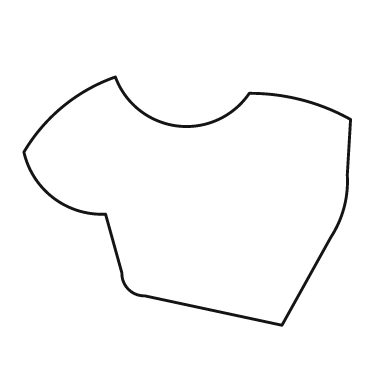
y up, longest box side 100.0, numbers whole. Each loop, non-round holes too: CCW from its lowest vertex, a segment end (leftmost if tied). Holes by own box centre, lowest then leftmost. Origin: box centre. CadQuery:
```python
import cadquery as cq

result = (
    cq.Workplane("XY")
    .moveTo(29.0, -38.0)
    .lineTo(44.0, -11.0)
    .threePointArc((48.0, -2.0), (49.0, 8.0))
    .lineTo(50.0, 25.0)
    .threePointArc((35.0, 31.0), (19.0, 33.0))
    .threePointArc((-3.0, 23.0), (-22.0, 38.0))
    .threePointArc((-38.0, 29.0), (-50.0, 15.0))
    .threePointArc((-41.0, 1.0), (-25.0, -4.0))
    .lineTo(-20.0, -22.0)
    .threePointArc((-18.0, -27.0), (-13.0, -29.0))
    .close()
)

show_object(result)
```